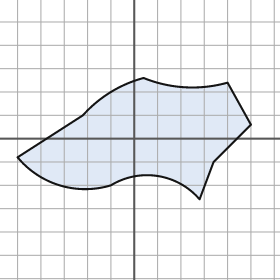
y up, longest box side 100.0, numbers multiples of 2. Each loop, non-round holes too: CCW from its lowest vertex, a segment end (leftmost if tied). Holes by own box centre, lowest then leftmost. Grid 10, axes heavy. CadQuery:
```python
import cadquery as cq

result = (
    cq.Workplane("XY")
    .moveTo(28.0, -26.0)
    .lineTo(34.0, -10.0)
    .lineTo(50.0, 6.0)
    .lineTo(40.0, 24.0)
    .threePointArc((22.0, 22.0), (4.0, 26.0))
    .threePointArc((-10.0, 20.0), (-22.0, 10.0))
    .lineTo(-50.0, -8.0)
    .threePointArc((-32.0, -20.0), (-10.0, -20.0))
    .threePointArc((10.0, -16.0), (28.0, -26.0))
    .close()
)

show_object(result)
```